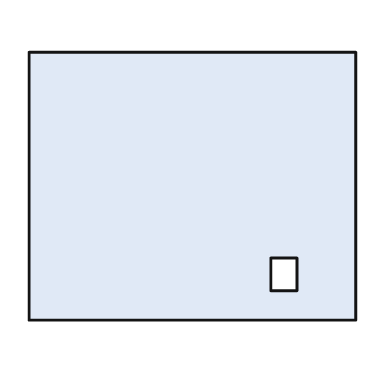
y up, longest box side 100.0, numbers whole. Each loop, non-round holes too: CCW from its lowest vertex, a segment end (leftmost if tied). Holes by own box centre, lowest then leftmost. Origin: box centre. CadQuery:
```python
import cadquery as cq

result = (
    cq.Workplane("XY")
    .moveTo(-50.0, -41.0)
    .lineTo(50.0, -41.0)
    .lineTo(50.0, 41.0)
    .lineTo(-50.0, 41.0)
    .close()
    .moveTo(24.0, -32.0)
    .lineTo(32.0, -32.0)
    .lineTo(32.0, -22.0)
    .lineTo(24.0, -22.0)
    .close()
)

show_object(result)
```